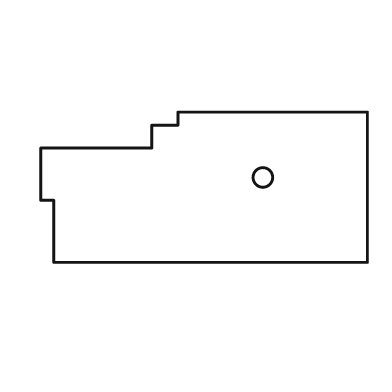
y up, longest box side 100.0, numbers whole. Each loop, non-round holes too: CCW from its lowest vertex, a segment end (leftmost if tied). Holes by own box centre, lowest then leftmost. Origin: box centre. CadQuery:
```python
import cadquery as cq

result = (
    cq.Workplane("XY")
    .moveTo(-46.0, -23.0)
    .lineTo(50.0, -23.0)
    .lineTo(50.0, 23.0)
    .lineTo(-8.0, 23.0)
    .lineTo(-8.0, 19.0)
    .lineTo(-16.0, 19.0)
    .lineTo(-16.0, 12.0)
    .lineTo(-50.0, 12.0)
    .lineTo(-50.0, -4.0)
    .lineTo(-46.0, -4.0)
    .close()
    .moveTo(18.0, 3.0)
    .circle(3.0)
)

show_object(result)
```